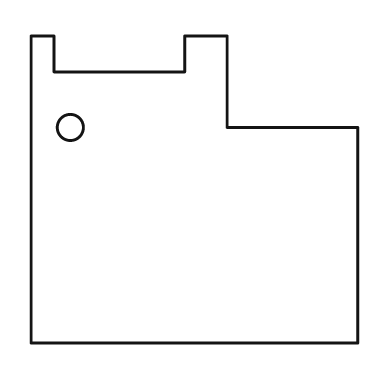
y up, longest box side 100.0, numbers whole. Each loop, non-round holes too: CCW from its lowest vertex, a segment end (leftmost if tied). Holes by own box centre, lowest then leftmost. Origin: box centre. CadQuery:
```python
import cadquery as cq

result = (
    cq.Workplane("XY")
    .moveTo(-50.0, -47.0)
    .lineTo(50.0, -47.0)
    .lineTo(50.0, 19.0)
    .lineTo(10.0, 19.0)
    .lineTo(10.0, 47.0)
    .lineTo(-3.0, 47.0)
    .lineTo(-3.0, 36.0)
    .lineTo(-43.0, 36.0)
    .lineTo(-43.0, 47.0)
    .lineTo(-50.0, 47.0)
    .close()
    .moveTo(-38.0, 19.0)
    .circle(4.0)
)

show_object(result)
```